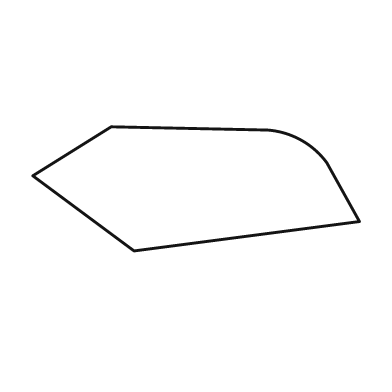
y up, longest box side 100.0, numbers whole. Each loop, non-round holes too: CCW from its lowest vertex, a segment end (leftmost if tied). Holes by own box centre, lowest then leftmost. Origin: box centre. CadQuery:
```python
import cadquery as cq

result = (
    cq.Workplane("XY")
    .moveTo(-19.0, -19.0)
    .lineTo(50.0, -10.0)
    .lineTo(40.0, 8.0)
    .threePointArc((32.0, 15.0), (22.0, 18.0))
    .lineTo(-26.0, 19.0)
    .lineTo(-50.0, 4.0)
    .close()
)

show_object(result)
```